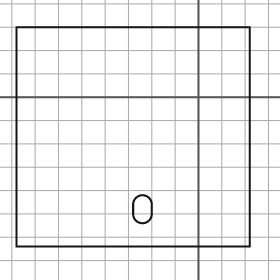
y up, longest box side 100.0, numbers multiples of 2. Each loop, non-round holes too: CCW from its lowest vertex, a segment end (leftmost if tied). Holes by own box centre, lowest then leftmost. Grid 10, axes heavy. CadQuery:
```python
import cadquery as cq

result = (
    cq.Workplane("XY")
    .moveTo(-78.0, -64.0)
    .lineTo(22.0, -64.0)
    .lineTo(22.0, 30.0)
    .lineTo(-78.0, 30.0)
    .close()
    .moveTo(-28.0, -50.0)
    .threePointArc((-24.0, -54.0), (-20.0, -50.0))
    .lineTo(-20.0, -46.0)
    .threePointArc((-24.0, -42.0), (-28.0, -46.0))
    .close()
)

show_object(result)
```